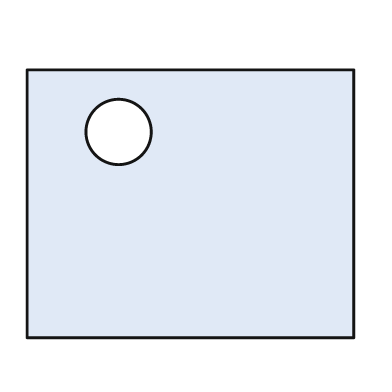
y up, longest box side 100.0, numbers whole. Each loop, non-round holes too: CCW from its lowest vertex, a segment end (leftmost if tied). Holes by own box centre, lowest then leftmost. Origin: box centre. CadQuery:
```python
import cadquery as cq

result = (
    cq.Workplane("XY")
    .moveTo(-50.0, -41.0)
    .lineTo(50.0, -41.0)
    .lineTo(50.0, 41.0)
    .lineTo(-50.0, 41.0)
    .close()
    .moveTo(-22.0, 22.0)
    .circle(10.0)
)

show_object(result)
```